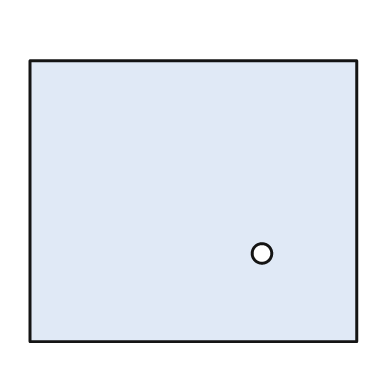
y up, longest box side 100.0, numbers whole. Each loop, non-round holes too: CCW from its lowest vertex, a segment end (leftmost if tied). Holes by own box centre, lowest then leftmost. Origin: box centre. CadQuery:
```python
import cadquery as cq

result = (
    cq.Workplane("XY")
    .moveTo(-50.0, -43.0)
    .lineTo(50.0, -43.0)
    .lineTo(50.0, 43.0)
    .lineTo(-50.0, 43.0)
    .close()
    .moveTo(21.0, -16.0)
    .circle(3.0)
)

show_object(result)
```